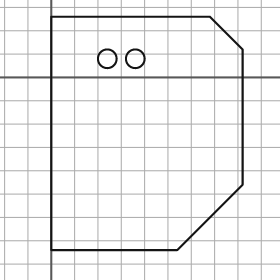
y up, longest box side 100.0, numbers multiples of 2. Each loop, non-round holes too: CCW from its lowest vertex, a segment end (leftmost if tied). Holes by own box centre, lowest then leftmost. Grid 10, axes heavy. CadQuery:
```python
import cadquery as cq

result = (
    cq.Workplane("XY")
    .moveTo(0.0, -74.0)
    .lineTo(54.0, -74.0)
    .lineTo(82.0, -46.0)
    .lineTo(82.0, 12.0)
    .lineTo(68.0, 26.0)
    .lineTo(0.0, 26.0)
    .close()
    .moveTo(24.0, 8.0)
    .circle(4.0)
    .moveTo(36.0, 8.0)
    .circle(4.0)
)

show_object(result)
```